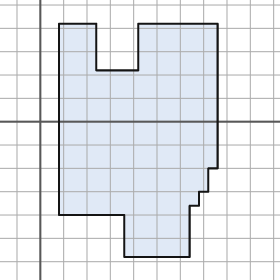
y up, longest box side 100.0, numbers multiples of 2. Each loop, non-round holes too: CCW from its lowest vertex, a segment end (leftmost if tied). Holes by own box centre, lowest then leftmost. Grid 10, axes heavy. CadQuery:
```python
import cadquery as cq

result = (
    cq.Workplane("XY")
    .moveTo(36.0, -58.0)
    .lineTo(64.0, -58.0)
    .lineTo(64.0, -36.0)
    .lineTo(68.0, -36.0)
    .lineTo(68.0, -30.0)
    .lineTo(72.0, -30.0)
    .lineTo(72.0, -20.0)
    .lineTo(76.0, -20.0)
    .lineTo(76.0, 42.0)
    .lineTo(42.0, 42.0)
    .lineTo(42.0, 22.0)
    .lineTo(24.0, 22.0)
    .lineTo(24.0, 42.0)
    .lineTo(8.0, 42.0)
    .lineTo(8.0, -40.0)
    .lineTo(36.0, -40.0)
    .close()
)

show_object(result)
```